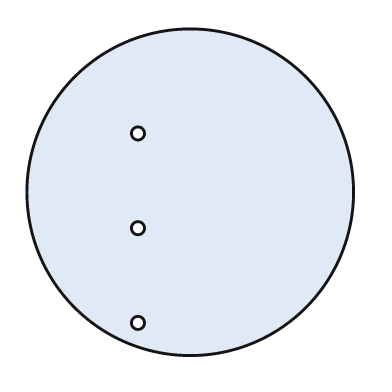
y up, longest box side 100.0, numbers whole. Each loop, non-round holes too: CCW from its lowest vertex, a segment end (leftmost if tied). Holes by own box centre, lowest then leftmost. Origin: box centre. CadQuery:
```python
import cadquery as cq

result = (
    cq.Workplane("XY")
    .moveTo(0.0, 0.0)
    .circle(50.0)
    .moveTo(-16.0, -40.0)
    .circle(2.0)
    .moveTo(-16.0, -11.0)
    .circle(2.0)
    .moveTo(-16.0, 18.0)
    .circle(2.0)
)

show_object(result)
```